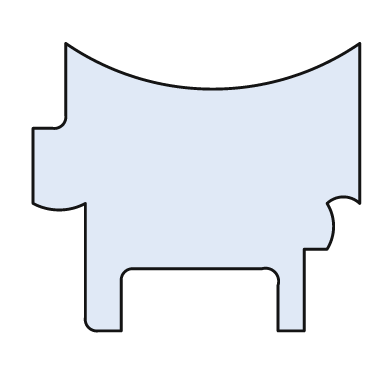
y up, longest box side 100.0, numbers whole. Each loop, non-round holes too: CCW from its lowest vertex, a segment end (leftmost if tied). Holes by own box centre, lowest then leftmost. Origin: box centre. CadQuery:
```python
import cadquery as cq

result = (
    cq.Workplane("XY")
    .moveTo(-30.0, -44.0)
    .lineTo(-23.0, -44.0)
    .lineTo(-23.0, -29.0)
    .threePointArc((-22.0, -26.0), (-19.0, -25.0))
    .lineTo(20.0, -25.0)
    .threePointArc((24.0, -26.0), (25.0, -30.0))
    .lineTo(25.0, -44.0)
    .lineTo(33.0, -44.0)
    .lineTo(33.0, -19.0)
    .lineTo(40.0, -19.0)
    .threePointArc((42.0, -12.0), (40.0, -5.0))
    .threePointArc((45.0, -3.0), (50.0, -5.0))
    .lineTo(50.0, 44.0)
    .threePointArc((5.0, 30.0), (-40.0, 44.0))
    .lineTo(-40.0, 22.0)
    .threePointArc((-41.0, 19.0), (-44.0, 18.0))
    .lineTo(-50.0, 18.0)
    .lineTo(-50.0, -5.0)
    .threePointArc((-42.0, -7.0), (-34.0, -5.0))
    .lineTo(-34.0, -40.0)
    .threePointArc((-33.0, -43.0), (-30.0, -44.0))
    .close()
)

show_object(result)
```